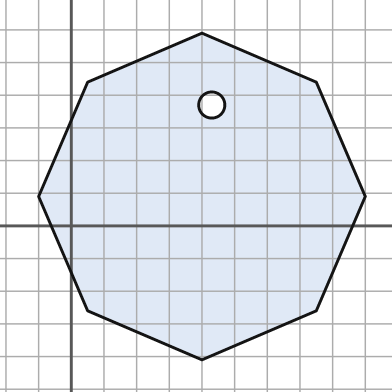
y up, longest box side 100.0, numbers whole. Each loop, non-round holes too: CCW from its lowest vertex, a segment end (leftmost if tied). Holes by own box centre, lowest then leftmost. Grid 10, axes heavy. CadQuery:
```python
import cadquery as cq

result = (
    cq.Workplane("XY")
    .moveTo(40.0, -41.0)
    .lineTo(75.0, -26.0)
    .lineTo(90.0, 9.0)
    .lineTo(75.0, 44.0)
    .lineTo(40.0, 59.0)
    .lineTo(5.0, 44.0)
    .lineTo(-10.0, 9.0)
    .lineTo(5.0, -26.0)
    .close()
    .moveTo(43.0, 37.0)
    .circle(4.0)
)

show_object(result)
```